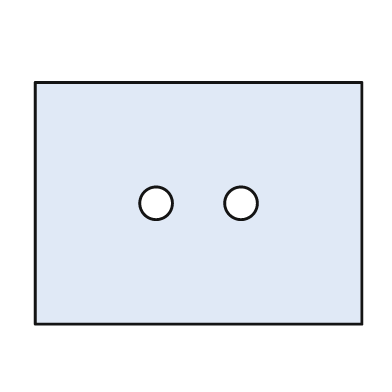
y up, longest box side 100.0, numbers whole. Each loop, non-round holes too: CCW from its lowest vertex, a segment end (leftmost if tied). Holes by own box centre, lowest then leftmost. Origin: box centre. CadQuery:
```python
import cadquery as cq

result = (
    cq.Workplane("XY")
    .moveTo(-50.0, -37.0)
    .lineTo(50.0, -37.0)
    .lineTo(50.0, 37.0)
    .lineTo(-50.0, 37.0)
    .close()
    .moveTo(-13.0, 0.0)
    .circle(5.0)
    .moveTo(13.0, 0.0)
    .circle(5.0)
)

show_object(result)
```